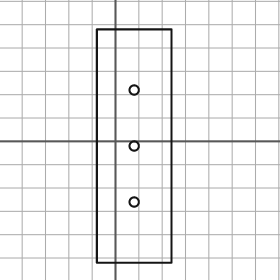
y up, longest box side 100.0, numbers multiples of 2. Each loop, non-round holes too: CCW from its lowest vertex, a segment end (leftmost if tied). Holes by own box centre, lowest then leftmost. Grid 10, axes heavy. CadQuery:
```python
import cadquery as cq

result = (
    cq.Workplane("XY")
    .moveTo(-8.0, -52.0)
    .lineTo(24.0, -52.0)
    .lineTo(24.0, 48.0)
    .lineTo(-8.0, 48.0)
    .close()
    .moveTo(8.0, -26.0)
    .circle(2.0)
    .moveTo(8.0, -2.0)
    .circle(2.0)
    .moveTo(8.0, 22.0)
    .circle(2.0)
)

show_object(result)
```